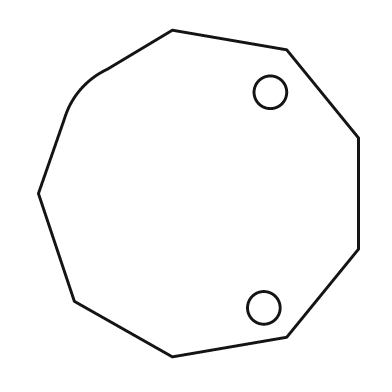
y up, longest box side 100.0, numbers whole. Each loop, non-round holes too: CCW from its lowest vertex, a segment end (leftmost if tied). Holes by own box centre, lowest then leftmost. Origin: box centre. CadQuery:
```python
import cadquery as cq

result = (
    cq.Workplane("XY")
    .moveTo(-8.0, -50.0)
    .lineTo(27.0, -44.0)
    .lineTo(49.0, -17.0)
    .lineTo(49.0, 17.0)
    .lineTo(27.0, 44.0)
    .lineTo(-8.0, 50.0)
    .lineTo(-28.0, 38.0)
    .threePointArc((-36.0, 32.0), (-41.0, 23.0))
    .lineTo(-49.0, 0.0)
    .lineTo(-38.0, -33.0)
    .close()
    .moveTo(20.0, -35.0)
    .circle(5.0)
    .moveTo(22.0, 31.0)
    .circle(5.0)
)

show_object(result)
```